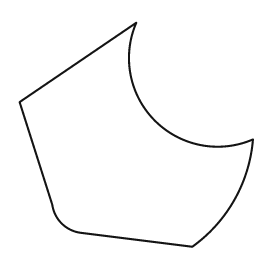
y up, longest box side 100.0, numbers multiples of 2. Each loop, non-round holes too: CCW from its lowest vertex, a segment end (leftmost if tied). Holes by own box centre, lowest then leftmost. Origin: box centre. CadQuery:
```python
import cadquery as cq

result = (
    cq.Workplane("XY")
    .moveTo(24.0, -48.0)
    .threePointArc((42.0, -28.0), (50.0, -2.0))
    .threePointArc((8.0, 6.0), (0.0, 48.0))
    .lineTo(-50.0, 14.0)
    .lineTo(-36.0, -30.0)
    .threePointArc((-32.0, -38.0), (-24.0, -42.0))
    .close()
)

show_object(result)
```